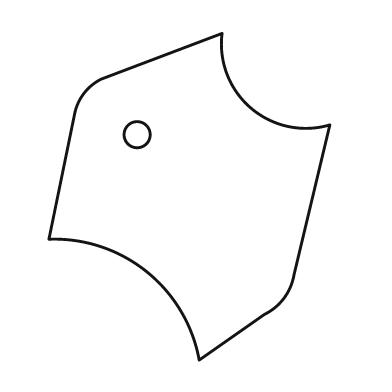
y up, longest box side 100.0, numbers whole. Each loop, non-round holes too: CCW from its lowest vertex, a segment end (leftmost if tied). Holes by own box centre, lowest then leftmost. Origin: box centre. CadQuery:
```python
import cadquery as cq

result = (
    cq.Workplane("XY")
    .moveTo(3.0, -50.0)
    .lineTo(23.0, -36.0)
    .threePointArc((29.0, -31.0), (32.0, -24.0))
    .lineTo(43.0, 22.0)
    .threePointArc((19.0, 27.0), (10.0, 50.0))
    .lineTo(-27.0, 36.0)
    .threePointArc((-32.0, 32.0), (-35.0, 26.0))
    .lineTo(-43.0, -13.0)
    .threePointArc((-13.0, -23.0), (3.0, -50.0))
    .close()
    .moveTo(-16.0, 19.0)
    .circle(4.0)
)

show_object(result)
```